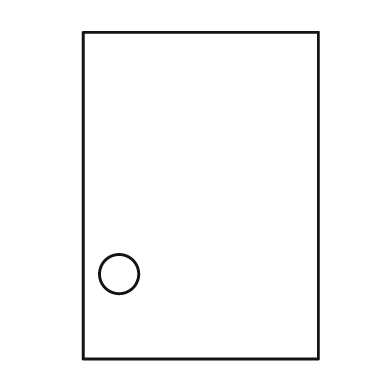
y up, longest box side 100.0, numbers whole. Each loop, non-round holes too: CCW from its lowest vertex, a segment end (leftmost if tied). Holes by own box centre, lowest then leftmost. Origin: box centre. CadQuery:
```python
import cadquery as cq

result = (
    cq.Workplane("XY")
    .moveTo(-36.0, -50.0)
    .lineTo(36.0, -50.0)
    .lineTo(36.0, 50.0)
    .lineTo(-36.0, 50.0)
    .close()
    .moveTo(-25.0, -24.0)
    .circle(6.0)
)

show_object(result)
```